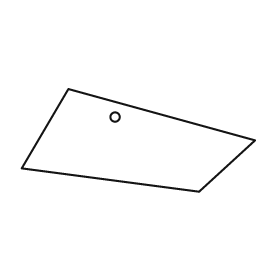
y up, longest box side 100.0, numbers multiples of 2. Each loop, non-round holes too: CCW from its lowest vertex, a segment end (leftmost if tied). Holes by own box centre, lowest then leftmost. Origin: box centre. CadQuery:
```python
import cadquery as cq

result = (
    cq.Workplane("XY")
    .moveTo(26.0, -22.0)
    .lineTo(50.0, 0.0)
    .lineTo(-30.0, 22.0)
    .lineTo(-50.0, -12.0)
    .close()
    .moveTo(-10.0, 10.0)
    .circle(2.0)
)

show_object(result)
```